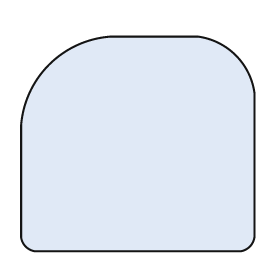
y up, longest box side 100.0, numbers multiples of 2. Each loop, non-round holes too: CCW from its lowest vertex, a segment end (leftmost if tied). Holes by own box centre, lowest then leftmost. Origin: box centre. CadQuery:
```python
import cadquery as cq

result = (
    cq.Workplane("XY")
    .moveTo(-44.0, -46.0)
    .lineTo(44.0, -46.0)
    .threePointArc((48.0, -44.0), (50.0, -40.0))
    .lineTo(50.0, 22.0)
    .threePointArc((42.0, 38.0), (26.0, 46.0))
    .lineTo(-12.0, 46.0)
    .threePointArc((-38.0, 34.0), (-50.0, 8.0))
    .lineTo(-50.0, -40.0)
    .threePointArc((-48.0, -44.0), (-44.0, -46.0))
    .close()
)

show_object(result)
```